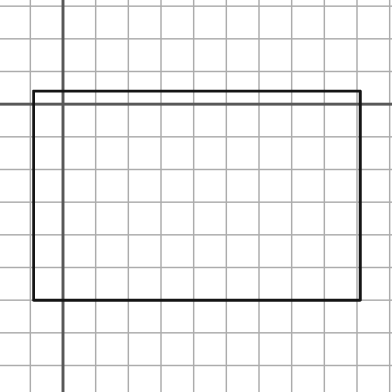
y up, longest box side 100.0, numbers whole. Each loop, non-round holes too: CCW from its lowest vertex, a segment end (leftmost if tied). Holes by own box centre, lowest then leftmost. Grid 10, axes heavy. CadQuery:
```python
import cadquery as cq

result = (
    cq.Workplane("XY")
    .moveTo(-9.0, -60.0)
    .lineTo(91.0, -60.0)
    .lineTo(91.0, 4.0)
    .lineTo(-9.0, 4.0)
    .close()
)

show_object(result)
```